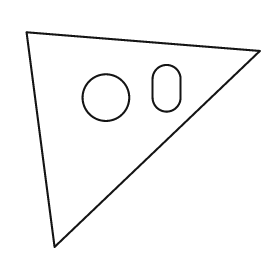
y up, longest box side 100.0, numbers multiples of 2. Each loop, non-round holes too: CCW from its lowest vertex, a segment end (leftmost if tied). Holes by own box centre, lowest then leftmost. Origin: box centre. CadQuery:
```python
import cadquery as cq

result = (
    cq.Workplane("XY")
    .moveTo(-38.0, -46.0)
    .lineTo(50.0, 38.0)
    .lineTo(-50.0, 46.0)
    .close()
    .moveTo(-16.0, 18.0)
    .circle(10.0)
    .moveTo(4.0, 18.0)
    .threePointArc((10.0, 12.0), (16.0, 18.0))
    .lineTo(16.0, 26.0)
    .threePointArc((10.0, 32.0), (4.0, 26.0))
    .close()
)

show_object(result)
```